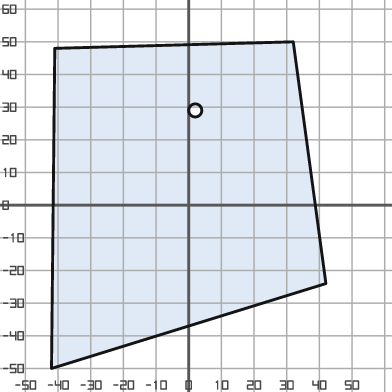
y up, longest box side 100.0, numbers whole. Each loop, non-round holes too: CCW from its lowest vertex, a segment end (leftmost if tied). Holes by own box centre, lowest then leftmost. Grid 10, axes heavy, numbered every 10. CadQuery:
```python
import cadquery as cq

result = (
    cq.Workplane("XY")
    .moveTo(-42.0, -50.0)
    .lineTo(42.0, -24.0)
    .lineTo(32.0, 50.0)
    .lineTo(-41.0, 48.0)
    .close()
    .moveTo(2.0, 29.0)
    .circle(2.0)
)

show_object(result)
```